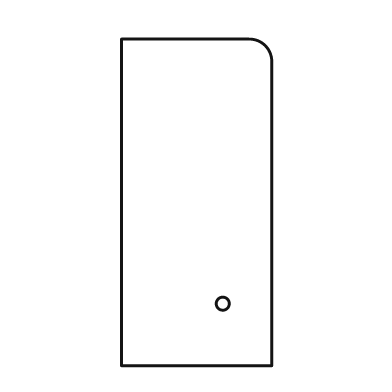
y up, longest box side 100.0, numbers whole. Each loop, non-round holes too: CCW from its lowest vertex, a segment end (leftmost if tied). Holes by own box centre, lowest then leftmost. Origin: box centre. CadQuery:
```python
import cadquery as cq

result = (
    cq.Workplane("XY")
    .moveTo(-23.0, -50.0)
    .lineTo(23.0, -50.0)
    .lineTo(23.0, 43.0)
    .threePointArc((21.0, 48.0), (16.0, 50.0))
    .lineTo(-23.0, 50.0)
    .close()
    .moveTo(8.0, -31.0)
    .circle(2.0)
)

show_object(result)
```